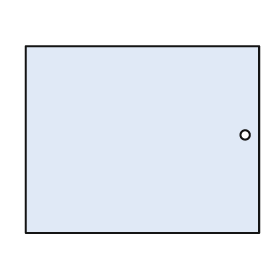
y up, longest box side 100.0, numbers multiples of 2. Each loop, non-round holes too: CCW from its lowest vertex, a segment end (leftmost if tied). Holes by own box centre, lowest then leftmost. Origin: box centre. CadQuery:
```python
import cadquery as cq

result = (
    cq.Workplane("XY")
    .moveTo(-50.0, -40.0)
    .lineTo(50.0, -40.0)
    .lineTo(50.0, 40.0)
    .lineTo(-50.0, 40.0)
    .close()
    .moveTo(44.0, 2.0)
    .circle(2.0)
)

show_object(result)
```